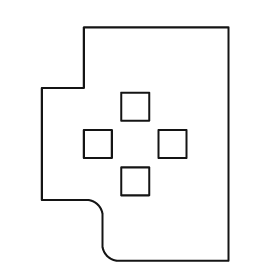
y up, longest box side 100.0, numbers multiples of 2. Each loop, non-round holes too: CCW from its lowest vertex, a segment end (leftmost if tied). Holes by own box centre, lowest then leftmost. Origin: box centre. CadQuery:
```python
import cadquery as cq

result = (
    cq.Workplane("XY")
    .moveTo(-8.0, -50.0)
    .lineTo(40.0, -50.0)
    .lineTo(40.0, 50.0)
    .lineTo(-22.0, 50.0)
    .lineTo(-22.0, 24.0)
    .lineTo(-40.0, 24.0)
    .lineTo(-40.0, -24.0)
    .lineTo(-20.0, -24.0)
    .threePointArc((-16.0, -26.0), (-14.0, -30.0))
    .lineTo(-14.0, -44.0)
    .threePointArc((-12.0, -48.0), (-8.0, -50.0))
    .close()
    .moveTo(-6.0, -22.0)
    .lineTo(6.0, -22.0)
    .lineTo(6.0, -10.0)
    .lineTo(-6.0, -10.0)
    .close()
    .moveTo(-22.0, -6.0)
    .lineTo(-10.0, -6.0)
    .lineTo(-10.0, 6.0)
    .lineTo(-22.0, 6.0)
    .close()
    .moveTo(10.0, -6.0)
    .lineTo(22.0, -6.0)
    .lineTo(22.0, 6.0)
    .lineTo(10.0, 6.0)
    .close()
    .moveTo(-6.0, 10.0)
    .lineTo(6.0, 10.0)
    .lineTo(6.0, 22.0)
    .lineTo(-6.0, 22.0)
    .close()
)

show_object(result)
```